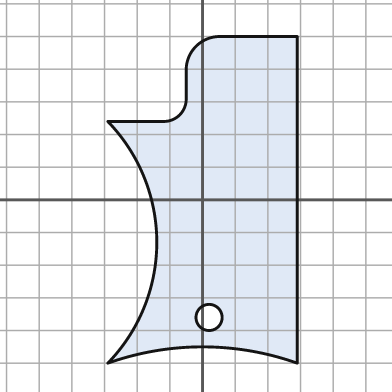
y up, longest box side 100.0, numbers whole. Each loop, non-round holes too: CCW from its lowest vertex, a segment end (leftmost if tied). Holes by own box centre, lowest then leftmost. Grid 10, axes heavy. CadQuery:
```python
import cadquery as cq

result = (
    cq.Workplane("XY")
    .moveTo(-29.0, -50.0)
    .threePointArc((0.0, -45.0), (29.0, -50.0))
    .lineTo(29.0, 50.0)
    .lineTo(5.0, 50.0)
    .threePointArc((-2.0, 47.0), (-5.0, 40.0))
    .lineTo(-5.0, 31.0)
    .threePointArc((-7.0, 26.0), (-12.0, 24.0))
    .lineTo(-29.0, 24.0)
    .threePointArc((-14.0, -13.0), (-29.0, -50.0))
    .close()
    .moveTo(2.0, -36.0)
    .circle(4.0)
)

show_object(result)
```